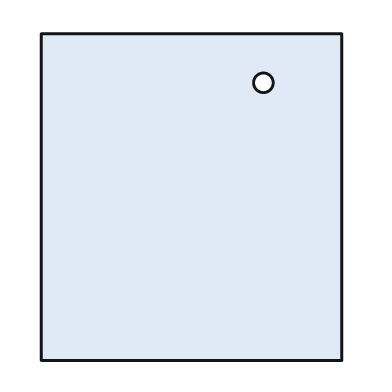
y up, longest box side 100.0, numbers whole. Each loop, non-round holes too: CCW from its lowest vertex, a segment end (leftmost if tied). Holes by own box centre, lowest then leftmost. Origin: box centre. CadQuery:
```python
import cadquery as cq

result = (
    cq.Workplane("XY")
    .moveTo(-46.0, -50.0)
    .lineTo(46.0, -50.0)
    .lineTo(46.0, 50.0)
    .lineTo(-46.0, 50.0)
    .close()
    .moveTo(22.0, 35.0)
    .circle(3.0)
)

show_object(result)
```